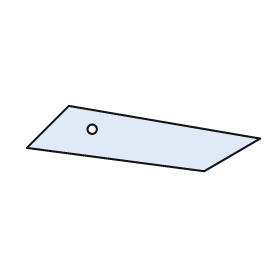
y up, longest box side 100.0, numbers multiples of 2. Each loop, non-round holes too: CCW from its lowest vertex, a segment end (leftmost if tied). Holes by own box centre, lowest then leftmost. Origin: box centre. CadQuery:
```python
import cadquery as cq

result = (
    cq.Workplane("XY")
    .moveTo(26.0, -14.0)
    .lineTo(50.0, 0.0)
    .lineTo(-32.0, 14.0)
    .lineTo(-50.0, -4.0)
    .close()
    .moveTo(-22.0, 4.0)
    .circle(2.0)
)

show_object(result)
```